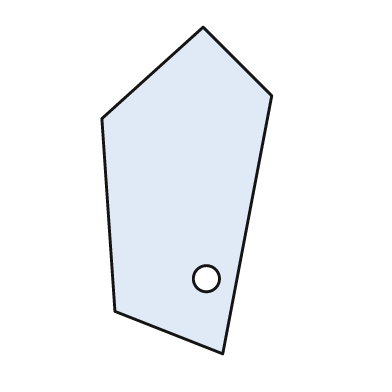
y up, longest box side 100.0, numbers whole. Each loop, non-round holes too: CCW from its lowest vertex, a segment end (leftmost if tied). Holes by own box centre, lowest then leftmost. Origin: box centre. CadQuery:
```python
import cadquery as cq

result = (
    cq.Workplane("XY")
    .moveTo(11.0, -50.0)
    .lineTo(26.0, 29.0)
    .lineTo(5.0, 50.0)
    .lineTo(-26.0, 22.0)
    .lineTo(-22.0, -37.0)
    .close()
    .moveTo(6.0, -27.0)
    .circle(4.0)
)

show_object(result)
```